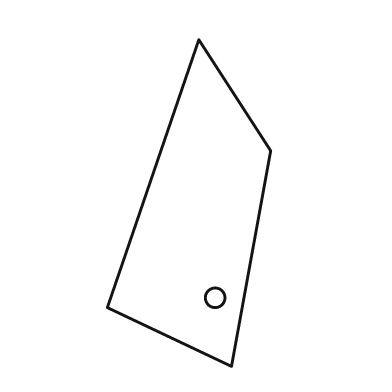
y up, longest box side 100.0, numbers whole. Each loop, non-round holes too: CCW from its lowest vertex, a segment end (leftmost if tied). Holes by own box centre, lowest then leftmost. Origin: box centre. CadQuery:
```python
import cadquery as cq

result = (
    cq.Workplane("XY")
    .moveTo(13.0, -50.0)
    .lineTo(25.0, 16.0)
    .lineTo(3.0, 50.0)
    .lineTo(-25.0, -32.0)
    .close()
    .moveTo(8.0, -29.0)
    .circle(3.0)
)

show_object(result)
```